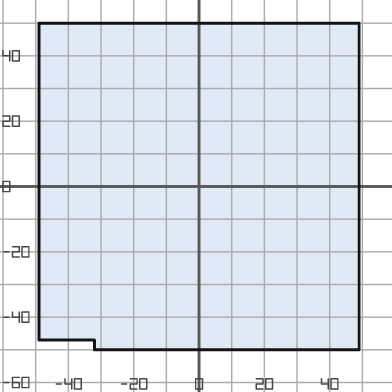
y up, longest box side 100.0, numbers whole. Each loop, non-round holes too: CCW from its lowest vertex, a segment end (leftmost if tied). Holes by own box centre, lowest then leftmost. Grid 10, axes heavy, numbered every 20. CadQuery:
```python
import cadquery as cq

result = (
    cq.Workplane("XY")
    .moveTo(-32.0, -50.0)
    .lineTo(49.0, -50.0)
    .lineTo(49.0, 50.0)
    .lineTo(-49.0, 50.0)
    .lineTo(-49.0, -47.0)
    .lineTo(-32.0, -47.0)
    .close()
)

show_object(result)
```